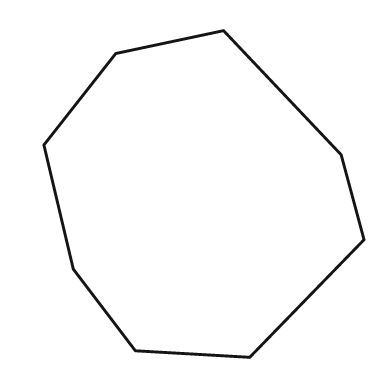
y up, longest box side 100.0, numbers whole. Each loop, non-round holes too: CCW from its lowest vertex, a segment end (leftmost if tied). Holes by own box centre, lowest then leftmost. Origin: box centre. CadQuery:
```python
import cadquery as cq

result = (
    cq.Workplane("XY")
    .moveTo(14.0, -50.0)
    .lineTo(49.0, -14.0)
    .lineTo(42.0, 12.0)
    .lineTo(6.0, 50.0)
    .lineTo(-27.0, 43.0)
    .lineTo(-49.0, 15.0)
    .lineTo(-40.0, -23.0)
    .lineTo(-21.0, -48.0)
    .close()
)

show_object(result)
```